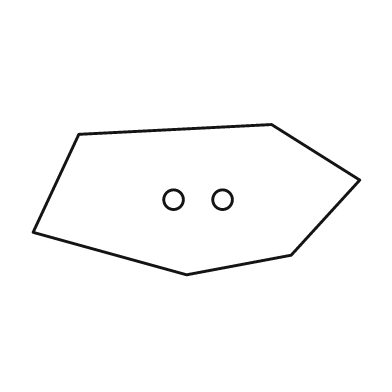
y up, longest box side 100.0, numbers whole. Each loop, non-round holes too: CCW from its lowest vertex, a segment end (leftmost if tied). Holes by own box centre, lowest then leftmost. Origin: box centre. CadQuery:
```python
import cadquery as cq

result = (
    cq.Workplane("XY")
    .moveTo(-3.0, -23.0)
    .lineTo(29.0, -17.0)
    .lineTo(50.0, 6.0)
    .lineTo(23.0, 23.0)
    .lineTo(-36.0, 20.0)
    .lineTo(-50.0, -10.0)
    .close()
    .moveTo(-7.0, 0.0)
    .circle(3.0)
    .moveTo(8.0, 0.0)
    .circle(3.0)
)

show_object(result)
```